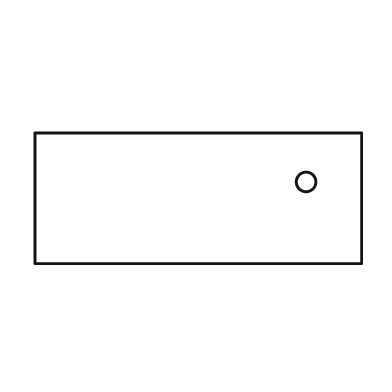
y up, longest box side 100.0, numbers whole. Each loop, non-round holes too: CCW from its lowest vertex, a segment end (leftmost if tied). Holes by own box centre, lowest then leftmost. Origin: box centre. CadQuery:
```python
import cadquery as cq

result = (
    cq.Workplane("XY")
    .moveTo(-50.0, -20.0)
    .lineTo(50.0, -20.0)
    .lineTo(50.0, 20.0)
    .lineTo(-50.0, 20.0)
    .close()
    .moveTo(33.0, 5.0)
    .circle(3.0)
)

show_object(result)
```